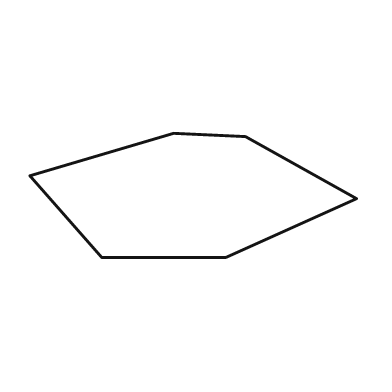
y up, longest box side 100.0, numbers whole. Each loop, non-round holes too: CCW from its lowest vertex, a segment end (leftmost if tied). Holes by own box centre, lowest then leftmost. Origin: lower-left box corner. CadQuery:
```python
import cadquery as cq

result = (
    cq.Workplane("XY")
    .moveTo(22.0, 0.0)
    .lineTo(60.0, 0.0)
    .lineTo(100.0, 18.0)
    .lineTo(66.0, 37.0)
    .lineTo(44.0, 38.0)
    .lineTo(0.0, 25.0)
    .close()
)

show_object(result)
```